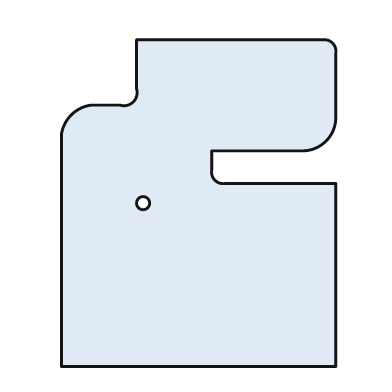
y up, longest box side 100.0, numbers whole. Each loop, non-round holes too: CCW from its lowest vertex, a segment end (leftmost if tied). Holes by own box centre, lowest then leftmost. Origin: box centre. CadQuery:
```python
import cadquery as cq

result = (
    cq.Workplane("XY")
    .moveTo(-42.0, -50.0)
    .lineTo(42.0, -50.0)
    .lineTo(42.0, 6.0)
    .lineTo(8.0, 6.0)
    .threePointArc((5.0, 7.0), (4.0, 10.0))
    .lineTo(4.0, 16.0)
    .lineTo(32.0, 16.0)
    .threePointArc((39.0, 19.0), (42.0, 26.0))
    .lineTo(42.0, 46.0)
    .threePointArc((41.0, 49.0), (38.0, 50.0))
    .lineTo(-19.0, 50.0)
    .lineTo(-19.0, 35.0)
    .threePointArc((-20.0, 31.0), (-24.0, 30.0))
    .lineTo(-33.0, 30.0)
    .threePointArc((-39.0, 27.0), (-42.0, 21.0))
    .close()
    .moveTo(-17.0, 0.0)
    .circle(2.0)
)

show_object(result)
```